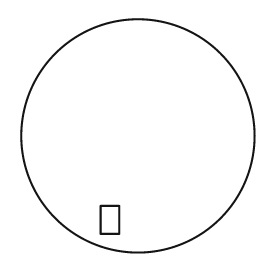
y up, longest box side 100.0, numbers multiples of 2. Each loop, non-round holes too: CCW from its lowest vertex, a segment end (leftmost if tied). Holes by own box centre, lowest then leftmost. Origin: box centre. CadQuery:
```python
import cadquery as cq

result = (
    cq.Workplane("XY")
    .moveTo(0.0, 0.0)
    .circle(50.0)
    .moveTo(-16.0, -42.0)
    .lineTo(-8.0, -42.0)
    .lineTo(-8.0, -30.0)
    .lineTo(-16.0, -30.0)
    .close()
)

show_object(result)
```